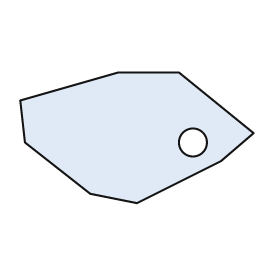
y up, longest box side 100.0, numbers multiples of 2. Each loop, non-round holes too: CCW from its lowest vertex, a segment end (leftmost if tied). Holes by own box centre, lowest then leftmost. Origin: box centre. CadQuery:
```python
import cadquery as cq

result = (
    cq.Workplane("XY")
    .moveTo(0.0, -28.0)
    .lineTo(36.0, -10.0)
    .lineTo(50.0, 2.0)
    .lineTo(18.0, 28.0)
    .lineTo(-8.0, 28.0)
    .lineTo(-50.0, 16.0)
    .lineTo(-48.0, -2.0)
    .lineTo(-20.0, -24.0)
    .close()
    .moveTo(24.0, -2.0)
    .circle(6.0)
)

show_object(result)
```